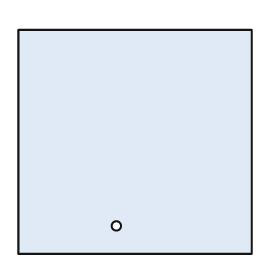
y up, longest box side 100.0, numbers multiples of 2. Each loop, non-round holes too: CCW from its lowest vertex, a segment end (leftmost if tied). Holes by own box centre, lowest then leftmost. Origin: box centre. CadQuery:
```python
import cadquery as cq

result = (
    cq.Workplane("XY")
    .moveTo(-50.0, -48.0)
    .lineTo(50.0, -48.0)
    .lineTo(50.0, 48.0)
    .lineTo(-50.0, 48.0)
    .close()
    .moveTo(-8.0, -36.0)
    .circle(2.0)
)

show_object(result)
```